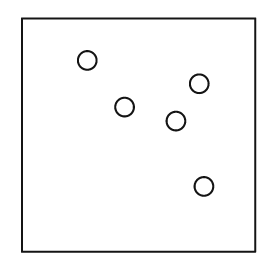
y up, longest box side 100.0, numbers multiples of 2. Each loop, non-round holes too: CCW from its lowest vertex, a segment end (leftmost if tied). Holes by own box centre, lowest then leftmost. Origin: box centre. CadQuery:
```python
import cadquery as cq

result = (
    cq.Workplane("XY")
    .moveTo(-50.0, -50.0)
    .lineTo(50.0, -50.0)
    .lineTo(50.0, 50.0)
    .lineTo(-50.0, 50.0)
    .close()
    .moveTo(28.0, -22.0)
    .circle(4.0)
    .moveTo(16.0, 6.0)
    .circle(4.0)
    .moveTo(-6.0, 12.0)
    .circle(4.0)
    .moveTo(26.0, 22.0)
    .circle(4.0)
    .moveTo(-22.0, 32.0)
    .circle(4.0)
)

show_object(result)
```